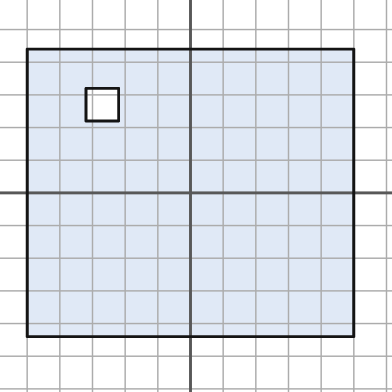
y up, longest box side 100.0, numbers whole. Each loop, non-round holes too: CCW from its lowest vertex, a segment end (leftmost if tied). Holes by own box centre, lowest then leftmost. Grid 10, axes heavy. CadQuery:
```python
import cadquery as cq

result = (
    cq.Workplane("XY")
    .moveTo(-50.0, -44.0)
    .lineTo(50.0, -44.0)
    .lineTo(50.0, 44.0)
    .lineTo(-50.0, 44.0)
    .close()
    .moveTo(-32.0, 22.0)
    .lineTo(-22.0, 22.0)
    .lineTo(-22.0, 32.0)
    .lineTo(-32.0, 32.0)
    .close()
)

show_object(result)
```